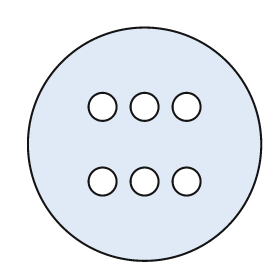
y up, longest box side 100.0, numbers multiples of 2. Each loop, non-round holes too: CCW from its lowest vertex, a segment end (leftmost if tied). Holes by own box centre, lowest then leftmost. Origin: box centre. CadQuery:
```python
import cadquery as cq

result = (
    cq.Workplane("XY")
    .moveTo(0.0, 0.0)
    .circle(50.0)
    .moveTo(-18.0, -16.0)
    .circle(6.0)
    .moveTo(0.0, -16.0)
    .circle(6.0)
    .moveTo(18.0, -16.0)
    .circle(6.0)
    .moveTo(-18.0, 16.0)
    .circle(6.0)
    .moveTo(0.0, 16.0)
    .circle(6.0)
    .moveTo(18.0, 16.0)
    .circle(6.0)
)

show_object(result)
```